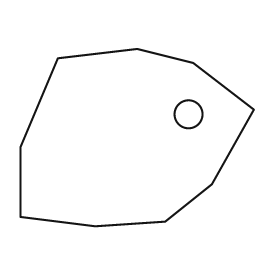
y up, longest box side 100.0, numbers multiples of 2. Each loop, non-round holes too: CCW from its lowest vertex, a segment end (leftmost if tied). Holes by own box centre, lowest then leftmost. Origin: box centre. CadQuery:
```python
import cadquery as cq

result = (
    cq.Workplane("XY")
    .moveTo(-18.0, -38.0)
    .lineTo(12.0, -36.0)
    .lineTo(32.0, -20.0)
    .lineTo(50.0, 12.0)
    .lineTo(24.0, 32.0)
    .lineTo(0.0, 38.0)
    .lineTo(-34.0, 34.0)
    .lineTo(-50.0, -4.0)
    .lineTo(-50.0, -34.0)
    .close()
    .moveTo(22.0, 10.0)
    .circle(6.0)
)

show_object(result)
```